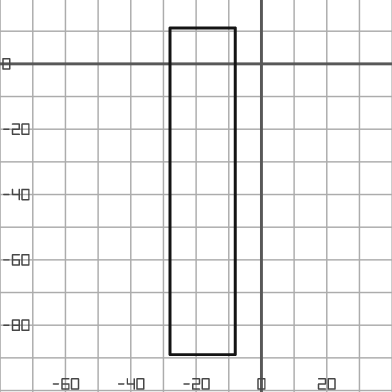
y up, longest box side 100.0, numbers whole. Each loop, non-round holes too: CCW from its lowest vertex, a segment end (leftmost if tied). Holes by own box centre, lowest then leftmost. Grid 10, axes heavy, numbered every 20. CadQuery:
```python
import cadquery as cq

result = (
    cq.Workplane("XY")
    .moveTo(-28.0, -89.0)
    .lineTo(-8.0, -89.0)
    .lineTo(-8.0, 11.0)
    .lineTo(-28.0, 11.0)
    .close()
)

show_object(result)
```